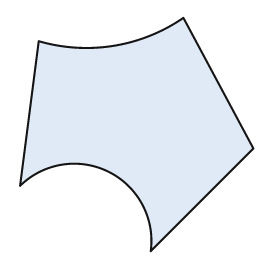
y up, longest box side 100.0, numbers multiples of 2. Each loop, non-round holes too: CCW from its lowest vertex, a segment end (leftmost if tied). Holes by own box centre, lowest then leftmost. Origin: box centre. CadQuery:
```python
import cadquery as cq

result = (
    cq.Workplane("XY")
    .moveTo(6.0, -50.0)
    .lineTo(50.0, -6.0)
    .lineTo(20.0, 50.0)
    .threePointArc((-10.0, 38.0), (-42.0, 40.0))
    .lineTo(-50.0, -22.0)
    .threePointArc((-12.0, -16.0), (6.0, -50.0))
    .close()
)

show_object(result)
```